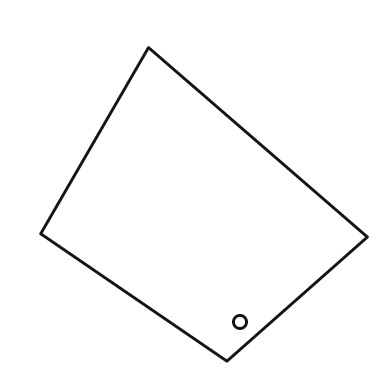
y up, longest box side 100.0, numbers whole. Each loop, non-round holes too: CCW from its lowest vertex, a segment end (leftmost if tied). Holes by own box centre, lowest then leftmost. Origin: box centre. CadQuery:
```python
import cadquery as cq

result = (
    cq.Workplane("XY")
    .moveTo(7.0, -48.0)
    .lineTo(50.0, -10.0)
    .lineTo(-17.0, 48.0)
    .lineTo(-50.0, -9.0)
    .close()
    .moveTo(11.0, -36.0)
    .circle(2.0)
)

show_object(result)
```